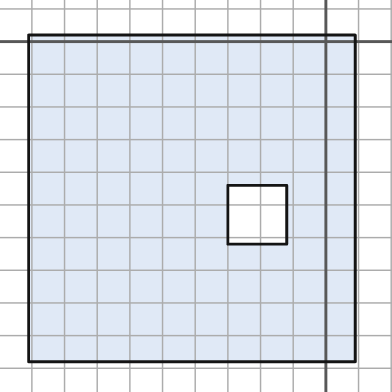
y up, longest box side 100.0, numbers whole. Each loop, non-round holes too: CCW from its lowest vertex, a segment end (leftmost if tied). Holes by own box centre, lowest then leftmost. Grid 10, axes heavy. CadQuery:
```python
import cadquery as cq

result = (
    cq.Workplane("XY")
    .moveTo(-91.0, -98.0)
    .lineTo(9.0, -98.0)
    .lineTo(9.0, 2.0)
    .lineTo(-91.0, 2.0)
    .close()
    .moveTo(-30.0, -62.0)
    .lineTo(-12.0, -62.0)
    .lineTo(-12.0, -44.0)
    .lineTo(-30.0, -44.0)
    .close()
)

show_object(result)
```